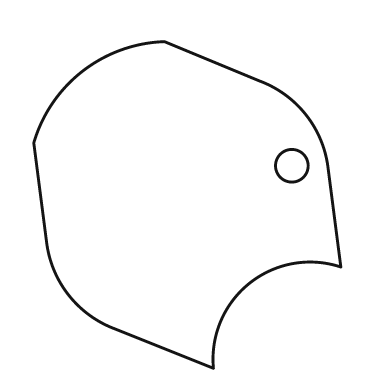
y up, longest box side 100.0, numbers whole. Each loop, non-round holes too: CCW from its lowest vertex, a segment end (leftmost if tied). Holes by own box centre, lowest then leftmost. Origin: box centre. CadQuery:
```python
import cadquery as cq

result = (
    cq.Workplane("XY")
    .moveTo(8.0, -50.0)
    .threePointArc((19.0, -24.0), (47.0, -19.0))
    .lineTo(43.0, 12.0)
    .threePointArc((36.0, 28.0), (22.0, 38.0))
    .lineTo(-7.0, 50.0)
    .threePointArc((-32.0, 41.0), (-47.0, 19.0))
    .lineTo(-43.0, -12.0)
    .threePointArc((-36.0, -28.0), (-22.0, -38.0))
    .close()
    .moveTo(32.0, 12.0)
    .circle(5.0)
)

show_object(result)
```